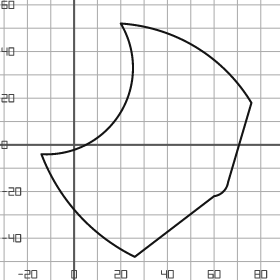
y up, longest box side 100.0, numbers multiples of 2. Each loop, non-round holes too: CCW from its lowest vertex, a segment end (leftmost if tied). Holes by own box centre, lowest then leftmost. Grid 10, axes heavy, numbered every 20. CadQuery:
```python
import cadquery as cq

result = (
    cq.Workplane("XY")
    .moveTo(26.0, -48.0)
    .lineTo(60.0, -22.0)
    .threePointArc((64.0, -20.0), (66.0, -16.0))
    .lineTo(76.0, 18.0)
    .threePointArc((52.0, 42.0), (20.0, 52.0))
    .threePointArc((20.0, 14.0), (-14.0, -4.0))
    .threePointArc((2.0, -30.0), (26.0, -48.0))
    .close()
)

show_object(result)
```